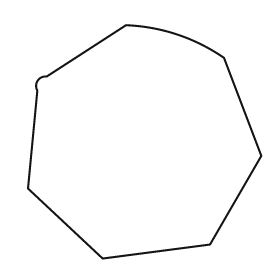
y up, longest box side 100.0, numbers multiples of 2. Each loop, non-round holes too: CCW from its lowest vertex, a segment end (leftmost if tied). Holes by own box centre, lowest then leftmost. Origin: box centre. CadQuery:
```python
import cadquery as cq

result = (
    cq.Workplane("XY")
    .moveTo(-18.0, -50.0)
    .lineTo(28.0, -44.0)
    .lineTo(50.0, -6.0)
    .lineTo(34.0, 36.0)
    .threePointArc((14.0, 46.0), (-8.0, 50.0))
    .lineTo(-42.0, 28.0)
    .threePointArc((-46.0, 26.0), (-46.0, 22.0))
    .lineTo(-50.0, -20.0)
    .close()
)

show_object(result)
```